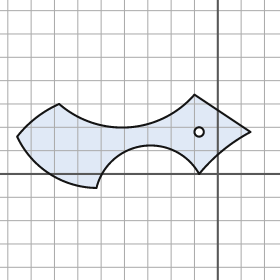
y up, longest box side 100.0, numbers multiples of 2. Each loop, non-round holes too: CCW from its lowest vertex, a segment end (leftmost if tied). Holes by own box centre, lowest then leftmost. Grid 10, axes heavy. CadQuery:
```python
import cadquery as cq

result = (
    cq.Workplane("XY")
    .moveTo(-52.0, -6.0)
    .threePointArc((-32.0, 12.0), (-8.0, 0.0))
    .threePointArc((2.0, 10.0), (14.0, 18.0))
    .lineTo(-10.0, 34.0)
    .threePointArc((-38.0, 20.0), (-68.0, 30.0))
    .threePointArc((-78.0, 24.0), (-86.0, 16.0))
    .threePointArc((-72.0, 0.0), (-52.0, -6.0))
    .close()
    .moveTo(-8.0, 18.0)
    .circle(2.0)
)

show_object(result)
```